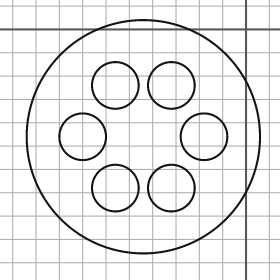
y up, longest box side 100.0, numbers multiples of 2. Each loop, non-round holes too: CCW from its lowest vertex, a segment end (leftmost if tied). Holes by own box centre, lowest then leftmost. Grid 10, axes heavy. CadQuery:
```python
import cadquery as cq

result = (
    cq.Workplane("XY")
    .moveTo(-44.0, -46.0)
    .circle(50.0)
    .moveTo(-56.0, -68.0)
    .circle(10.0)
    .moveTo(-32.0, -68.0)
    .circle(10.0)
    .moveTo(-70.0, -46.0)
    .circle(10.0)
    .moveTo(-18.0, -46.0)
    .circle(10.0)
    .moveTo(-56.0, -24.0)
    .circle(10.0)
    .moveTo(-32.0, -24.0)
    .circle(10.0)
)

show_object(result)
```